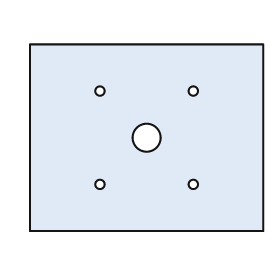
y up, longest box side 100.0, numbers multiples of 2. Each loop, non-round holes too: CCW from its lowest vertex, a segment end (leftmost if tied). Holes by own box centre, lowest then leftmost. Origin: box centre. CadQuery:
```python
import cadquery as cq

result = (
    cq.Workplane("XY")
    .moveTo(-50.0, -40.0)
    .lineTo(50.0, -40.0)
    .lineTo(50.0, 40.0)
    .lineTo(-50.0, 40.0)
    .close()
    .moveTo(-20.0, -20.0)
    .circle(2.0)
    .moveTo(20.0, -20.0)
    .circle(2.0)
    .moveTo(0.0, 0.0)
    .circle(6.0)
    .moveTo(-20.0, 20.0)
    .circle(2.0)
    .moveTo(20.0, 20.0)
    .circle(2.0)
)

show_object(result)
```